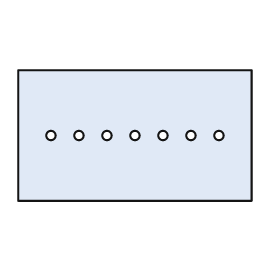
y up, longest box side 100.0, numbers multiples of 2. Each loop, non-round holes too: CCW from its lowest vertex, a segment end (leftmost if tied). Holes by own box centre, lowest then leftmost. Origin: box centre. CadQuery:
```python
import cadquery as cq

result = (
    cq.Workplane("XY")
    .moveTo(-50.0, -28.0)
    .lineTo(50.0, -28.0)
    .lineTo(50.0, 28.0)
    .lineTo(-50.0, 28.0)
    .close()
    .moveTo(-36.0, 0.0)
    .circle(2.0)
    .moveTo(-24.0, 0.0)
    .circle(2.0)
    .moveTo(-12.0, 0.0)
    .circle(2.0)
    .moveTo(0.0, 0.0)
    .circle(2.0)
    .moveTo(12.0, 0.0)
    .circle(2.0)
    .moveTo(24.0, 0.0)
    .circle(2.0)
    .moveTo(36.0, 0.0)
    .circle(2.0)
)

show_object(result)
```